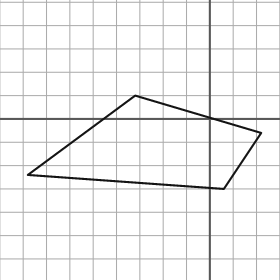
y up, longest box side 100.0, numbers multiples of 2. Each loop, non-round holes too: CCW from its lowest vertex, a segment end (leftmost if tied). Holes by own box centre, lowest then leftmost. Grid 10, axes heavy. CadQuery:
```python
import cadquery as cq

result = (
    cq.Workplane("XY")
    .moveTo(6.0, -30.0)
    .lineTo(22.0, -6.0)
    .lineTo(-32.0, 10.0)
    .lineTo(-78.0, -24.0)
    .close()
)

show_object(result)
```